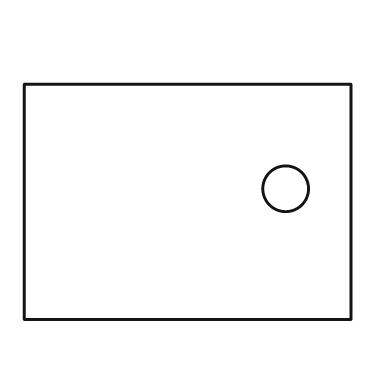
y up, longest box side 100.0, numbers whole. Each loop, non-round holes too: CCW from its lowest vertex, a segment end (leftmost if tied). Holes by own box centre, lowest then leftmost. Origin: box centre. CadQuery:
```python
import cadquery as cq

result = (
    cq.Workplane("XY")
    .moveTo(-50.0, -36.0)
    .lineTo(50.0, -36.0)
    .lineTo(50.0, 36.0)
    .lineTo(-50.0, 36.0)
    .close()
    .moveTo(30.0, 4.0)
    .circle(7.0)
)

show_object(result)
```